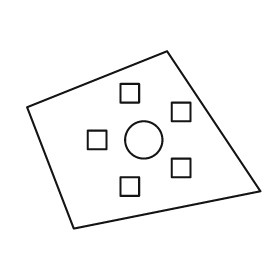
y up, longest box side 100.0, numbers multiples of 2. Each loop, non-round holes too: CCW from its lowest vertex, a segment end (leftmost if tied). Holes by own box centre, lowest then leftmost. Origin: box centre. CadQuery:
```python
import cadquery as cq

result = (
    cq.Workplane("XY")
    .moveTo(-30.0, -38.0)
    .lineTo(50.0, -22.0)
    .lineTo(10.0, 38.0)
    .lineTo(-50.0, 14.0)
    .close()
    .moveTo(-10.0, -24.0)
    .lineTo(-2.0, -24.0)
    .lineTo(-2.0, -16.0)
    .lineTo(-10.0, -16.0)
    .close()
    .moveTo(12.0, -16.0)
    .lineTo(20.0, -16.0)
    .lineTo(20.0, -8.0)
    .lineTo(12.0, -8.0)
    .close()
    .moveTo(-24.0, -4.0)
    .lineTo(-16.0, -4.0)
    .lineTo(-16.0, 4.0)
    .lineTo(-24.0, 4.0)
    .close()
    .moveTo(0.0, 0.0)
    .circle(8.0)
    .moveTo(12.0, 8.0)
    .lineTo(20.0, 8.0)
    .lineTo(20.0, 16.0)
    .lineTo(12.0, 16.0)
    .close()
    .moveTo(-10.0, 16.0)
    .lineTo(-2.0, 16.0)
    .lineTo(-2.0, 24.0)
    .lineTo(-10.0, 24.0)
    .close()
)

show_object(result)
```